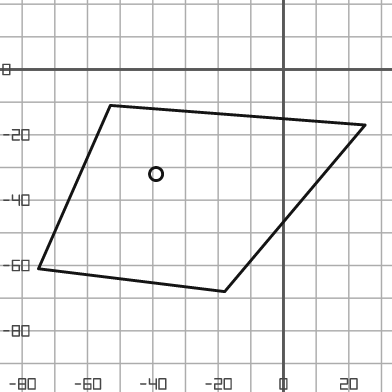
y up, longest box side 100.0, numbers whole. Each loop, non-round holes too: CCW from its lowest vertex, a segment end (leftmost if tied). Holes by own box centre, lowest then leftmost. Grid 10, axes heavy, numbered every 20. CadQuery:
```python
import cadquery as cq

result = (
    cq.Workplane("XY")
    .moveTo(-18.0, -68.0)
    .lineTo(25.0, -17.0)
    .lineTo(-53.0, -11.0)
    .lineTo(-75.0, -61.0)
    .close()
    .moveTo(-39.0, -32.0)
    .circle(2.0)
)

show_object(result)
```